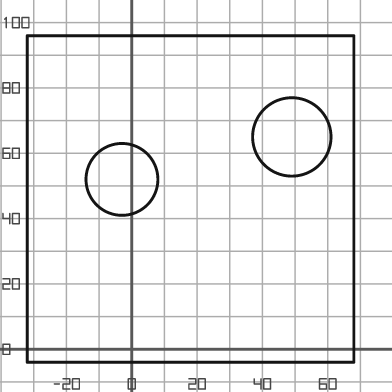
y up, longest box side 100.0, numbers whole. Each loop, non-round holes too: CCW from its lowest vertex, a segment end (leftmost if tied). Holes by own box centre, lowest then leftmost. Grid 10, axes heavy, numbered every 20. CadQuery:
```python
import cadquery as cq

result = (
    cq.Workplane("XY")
    .moveTo(-32.0, -4.0)
    .lineTo(68.0, -4.0)
    .lineTo(68.0, 96.0)
    .lineTo(-32.0, 96.0)
    .close()
    .moveTo(-3.0, 52.0)
    .circle(11.0)
    .moveTo(49.0, 65.0)
    .circle(12.0)
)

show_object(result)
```